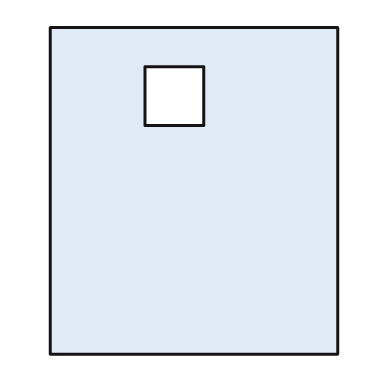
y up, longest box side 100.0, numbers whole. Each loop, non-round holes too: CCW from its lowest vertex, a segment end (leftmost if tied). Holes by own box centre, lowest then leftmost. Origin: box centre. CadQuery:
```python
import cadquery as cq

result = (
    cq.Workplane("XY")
    .moveTo(-44.0, -50.0)
    .lineTo(44.0, -50.0)
    .lineTo(44.0, 50.0)
    .lineTo(-44.0, 50.0)
    .close()
    .moveTo(-15.0, 20.0)
    .lineTo(3.0, 20.0)
    .lineTo(3.0, 38.0)
    .lineTo(-15.0, 38.0)
    .close()
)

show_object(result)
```